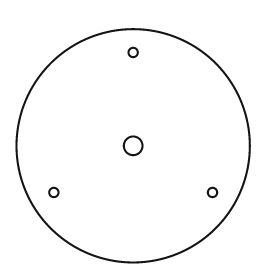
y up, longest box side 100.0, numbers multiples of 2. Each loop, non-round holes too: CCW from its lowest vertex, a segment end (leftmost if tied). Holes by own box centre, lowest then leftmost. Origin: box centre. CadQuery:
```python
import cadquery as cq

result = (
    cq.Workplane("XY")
    .moveTo(0.0, 0.0)
    .circle(50.0)
    .moveTo(-34.0, -20.0)
    .circle(2.0)
    .moveTo(34.0, -20.0)
    .circle(2.0)
    .moveTo(0.0, 0.0)
    .circle(4.0)
    .moveTo(0.0, 40.0)
    .circle(2.0)
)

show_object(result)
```